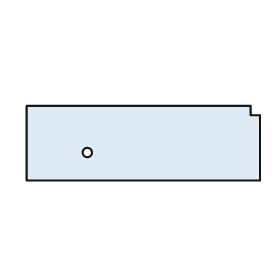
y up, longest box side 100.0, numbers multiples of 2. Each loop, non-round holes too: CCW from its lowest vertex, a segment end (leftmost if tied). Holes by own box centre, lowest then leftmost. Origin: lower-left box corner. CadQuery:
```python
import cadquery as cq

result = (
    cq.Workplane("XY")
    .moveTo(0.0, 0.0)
    .lineTo(100.0, 0.0)
    .lineTo(100.0, 28.0)
    .lineTo(96.0, 28.0)
    .lineTo(96.0, 32.0)
    .lineTo(0.0, 32.0)
    .close()
    .moveTo(26.0, 12.0)
    .circle(2.0)
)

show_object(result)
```